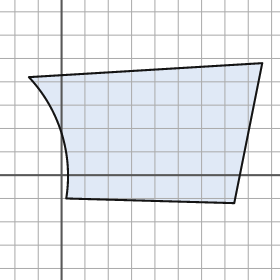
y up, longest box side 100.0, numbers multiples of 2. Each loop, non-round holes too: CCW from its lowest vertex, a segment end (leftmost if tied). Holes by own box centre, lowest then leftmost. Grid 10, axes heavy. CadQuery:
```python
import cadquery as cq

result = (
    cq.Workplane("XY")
    .moveTo(74.0, -12.0)
    .lineTo(86.0, 48.0)
    .lineTo(-14.0, 42.0)
    .threePointArc((0.0, 18.0), (2.0, -10.0))
    .close()
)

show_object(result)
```